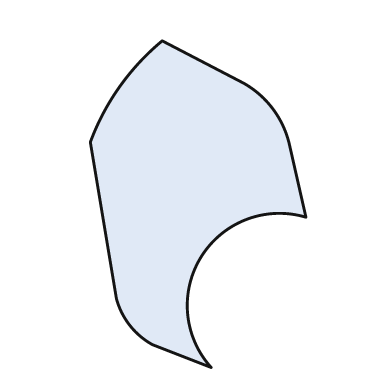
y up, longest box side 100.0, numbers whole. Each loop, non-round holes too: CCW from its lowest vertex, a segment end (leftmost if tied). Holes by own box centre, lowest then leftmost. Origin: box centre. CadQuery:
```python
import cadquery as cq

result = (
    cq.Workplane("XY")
    .moveTo(4.0, -50.0)
    .threePointArc((1.0, -16.0), (33.0, -4.0))
    .lineTo(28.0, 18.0)
    .threePointArc((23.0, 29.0), (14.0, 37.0))
    .lineTo(-11.0, 50.0)
    .threePointArc((-24.0, 36.0), (-33.0, 19.0))
    .lineTo(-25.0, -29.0)
    .threePointArc((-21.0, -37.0), (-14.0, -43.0))
    .close()
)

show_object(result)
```